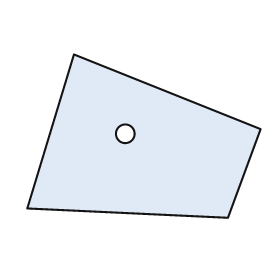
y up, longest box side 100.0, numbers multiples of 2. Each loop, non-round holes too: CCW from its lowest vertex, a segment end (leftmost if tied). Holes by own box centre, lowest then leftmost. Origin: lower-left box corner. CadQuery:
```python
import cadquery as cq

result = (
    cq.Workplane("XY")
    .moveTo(86.0, 0.0)
    .lineTo(100.0, 38.0)
    .lineTo(20.0, 70.0)
    .lineTo(0.0, 4.0)
    .close()
    .moveTo(42.0, 36.0)
    .circle(4.0)
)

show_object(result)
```